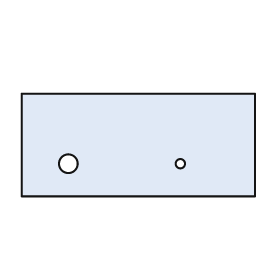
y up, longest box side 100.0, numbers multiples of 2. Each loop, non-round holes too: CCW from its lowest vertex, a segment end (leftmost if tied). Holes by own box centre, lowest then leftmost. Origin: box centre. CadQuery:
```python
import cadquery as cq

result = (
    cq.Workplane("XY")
    .moveTo(-50.0, -22.0)
    .lineTo(50.0, -22.0)
    .lineTo(50.0, 22.0)
    .lineTo(-50.0, 22.0)
    .close()
    .moveTo(-30.0, -8.0)
    .circle(4.0)
    .moveTo(18.0, -8.0)
    .circle(2.0)
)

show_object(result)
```